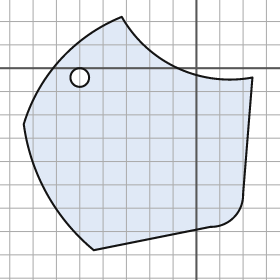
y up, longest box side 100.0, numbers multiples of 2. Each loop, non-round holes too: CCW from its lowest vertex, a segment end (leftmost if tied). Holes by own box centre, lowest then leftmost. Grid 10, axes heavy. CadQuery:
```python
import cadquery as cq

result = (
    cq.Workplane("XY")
    .moveTo(-44.0, -78.0)
    .lineTo(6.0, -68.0)
    .threePointArc((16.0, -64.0), (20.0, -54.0))
    .lineTo(24.0, -4.0)
    .threePointArc((-8.0, 0.0), (-32.0, 22.0))
    .threePointArc((-58.0, 4.0), (-74.0, -24.0))
    .threePointArc((-64.0, -54.0), (-44.0, -78.0))
    .close()
    .moveTo(-50.0, -4.0)
    .circle(4.0)
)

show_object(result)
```